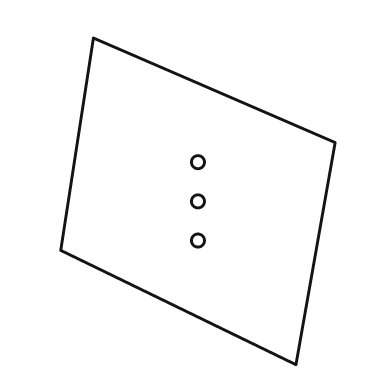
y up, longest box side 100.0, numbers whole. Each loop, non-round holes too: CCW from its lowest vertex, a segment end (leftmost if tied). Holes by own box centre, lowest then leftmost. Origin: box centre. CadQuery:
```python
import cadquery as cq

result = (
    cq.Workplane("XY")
    .moveTo(30.0, -50.0)
    .lineTo(42.0, 18.0)
    .lineTo(-32.0, 50.0)
    .lineTo(-42.0, -15.0)
    .close()
    .moveTo(0.0, -12.0)
    .circle(2.0)
    .moveTo(0.0, 0.0)
    .circle(2.0)
    .moveTo(0.0, 12.0)
    .circle(2.0)
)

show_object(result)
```